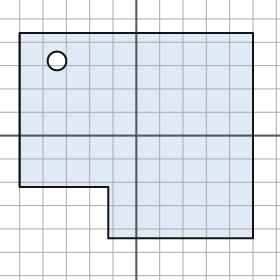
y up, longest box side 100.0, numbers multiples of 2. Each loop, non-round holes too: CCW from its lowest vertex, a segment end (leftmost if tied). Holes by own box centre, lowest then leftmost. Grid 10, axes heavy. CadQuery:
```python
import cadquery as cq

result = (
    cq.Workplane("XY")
    .moveTo(-12.0, -44.0)
    .lineTo(50.0, -44.0)
    .lineTo(50.0, 44.0)
    .lineTo(-50.0, 44.0)
    .lineTo(-50.0, -22.0)
    .lineTo(-12.0, -22.0)
    .close()
    .moveTo(-34.0, 32.0)
    .circle(4.0)
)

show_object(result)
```